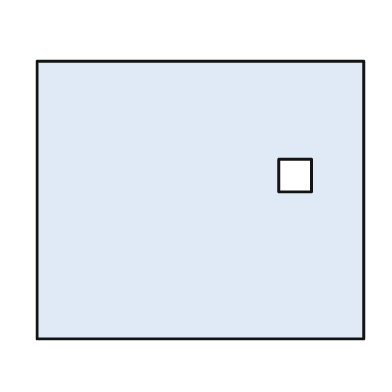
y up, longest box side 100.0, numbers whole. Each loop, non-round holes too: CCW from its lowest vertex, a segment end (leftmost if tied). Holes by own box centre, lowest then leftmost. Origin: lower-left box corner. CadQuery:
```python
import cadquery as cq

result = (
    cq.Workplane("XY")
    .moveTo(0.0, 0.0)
    .lineTo(100.0, 0.0)
    .lineTo(100.0, 85.0)
    .lineTo(0.0, 85.0)
    .close()
    .moveTo(74.0, 45.0)
    .lineTo(84.0, 45.0)
    .lineTo(84.0, 55.0)
    .lineTo(74.0, 55.0)
    .close()
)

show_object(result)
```